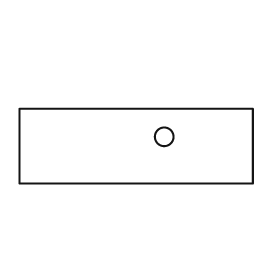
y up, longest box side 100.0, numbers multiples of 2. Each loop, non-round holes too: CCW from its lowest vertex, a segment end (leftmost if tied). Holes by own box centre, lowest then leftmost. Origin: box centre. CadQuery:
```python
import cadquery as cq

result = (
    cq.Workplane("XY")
    .moveTo(-50.0, -16.0)
    .lineTo(50.0, -16.0)
    .lineTo(50.0, 16.0)
    .lineTo(-50.0, 16.0)
    .close()
    .moveTo(12.0, 4.0)
    .circle(4.0)
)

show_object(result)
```